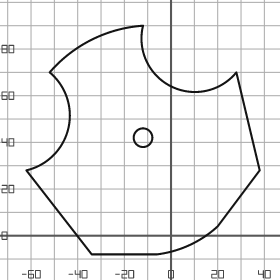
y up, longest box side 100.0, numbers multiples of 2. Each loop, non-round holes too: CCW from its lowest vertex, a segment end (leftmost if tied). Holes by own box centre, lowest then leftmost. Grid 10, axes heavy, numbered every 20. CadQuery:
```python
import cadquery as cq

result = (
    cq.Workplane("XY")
    .moveTo(-34.0, -8.0)
    .lineTo(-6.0, -8.0)
    .threePointArc((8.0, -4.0), (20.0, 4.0))
    .lineTo(38.0, 28.0)
    .lineTo(28.0, 70.0)
    .threePointArc((0.0, 64.0), (-12.0, 90.0))
    .threePointArc((-34.0, 84.0), (-52.0, 70.0))
    .threePointArc((-44.0, 46.0), (-62.0, 28.0))
    .close()
    .moveTo(-12.0, 42.0)
    .circle(4.0)
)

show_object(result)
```